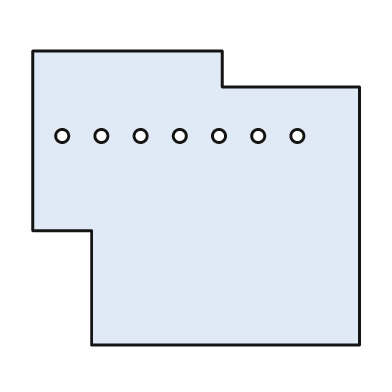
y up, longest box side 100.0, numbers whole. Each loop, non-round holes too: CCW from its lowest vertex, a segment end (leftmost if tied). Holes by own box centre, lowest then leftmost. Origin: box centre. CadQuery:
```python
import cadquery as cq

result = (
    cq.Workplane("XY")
    .moveTo(-32.0, -45.0)
    .lineTo(50.0, -45.0)
    .lineTo(50.0, 34.0)
    .lineTo(8.0, 34.0)
    .lineTo(8.0, 45.0)
    .lineTo(-50.0, 45.0)
    .lineTo(-50.0, -10.0)
    .lineTo(-32.0, -10.0)
    .close()
    .moveTo(-41.0, 19.0)
    .circle(2.0)
    .moveTo(-29.0, 19.0)
    .circle(2.0)
    .moveTo(-17.0, 19.0)
    .circle(2.0)
    .moveTo(-5.0, 19.0)
    .circle(2.0)
    .moveTo(7.0, 19.0)
    .circle(2.0)
    .moveTo(19.0, 19.0)
    .circle(2.0)
    .moveTo(31.0, 19.0)
    .circle(2.0)
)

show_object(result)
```